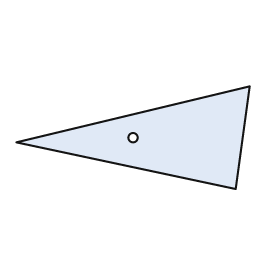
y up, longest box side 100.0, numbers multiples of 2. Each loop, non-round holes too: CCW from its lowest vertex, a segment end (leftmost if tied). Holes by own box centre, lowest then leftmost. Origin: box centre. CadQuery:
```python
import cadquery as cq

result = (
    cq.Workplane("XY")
    .moveTo(44.0, -22.0)
    .lineTo(50.0, 22.0)
    .lineTo(-50.0, -2.0)
    .close()
    .moveTo(0.0, 0.0)
    .circle(2.0)
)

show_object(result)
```